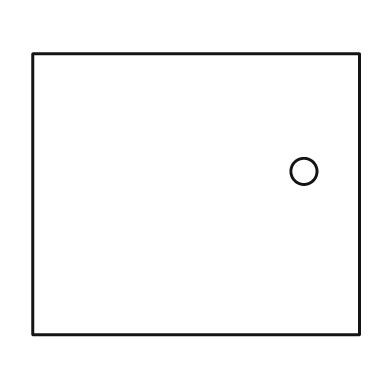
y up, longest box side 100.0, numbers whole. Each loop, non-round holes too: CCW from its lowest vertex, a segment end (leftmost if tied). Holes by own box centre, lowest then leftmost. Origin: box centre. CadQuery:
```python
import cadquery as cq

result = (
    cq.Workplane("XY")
    .moveTo(-50.0, -43.0)
    .lineTo(50.0, -43.0)
    .lineTo(50.0, 43.0)
    .lineTo(-50.0, 43.0)
    .close()
    .moveTo(33.0, 7.0)
    .circle(4.0)
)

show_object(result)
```